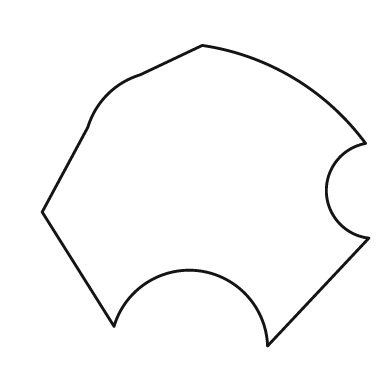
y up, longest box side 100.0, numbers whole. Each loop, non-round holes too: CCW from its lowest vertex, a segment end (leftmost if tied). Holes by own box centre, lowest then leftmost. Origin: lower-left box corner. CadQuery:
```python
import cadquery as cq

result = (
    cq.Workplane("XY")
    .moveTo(69.0, 0.0)
    .lineTo(100.0, 33.0)
    .threePointArc((87.0, 47.0), (99.0, 62.0))
    .threePointArc((77.0, 82.0), (49.0, 92.0))
    .lineTo(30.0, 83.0)
    .threePointArc((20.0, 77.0), (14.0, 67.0))
    .lineTo(0.0, 41.0)
    .lineTo(22.0, 6.0)
    .threePointArc((48.0, 23.0), (69.0, 0.0))
    .close()
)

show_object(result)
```